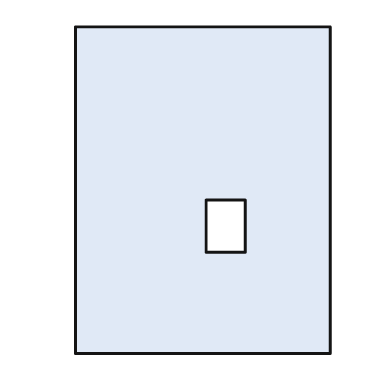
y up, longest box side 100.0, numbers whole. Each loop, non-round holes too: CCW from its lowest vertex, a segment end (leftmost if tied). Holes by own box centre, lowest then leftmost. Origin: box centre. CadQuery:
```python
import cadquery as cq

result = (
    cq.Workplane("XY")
    .moveTo(-39.0, -50.0)
    .lineTo(39.0, -50.0)
    .lineTo(39.0, 50.0)
    .lineTo(-39.0, 50.0)
    .close()
    .moveTo(1.0, -19.0)
    .lineTo(13.0, -19.0)
    .lineTo(13.0, -3.0)
    .lineTo(1.0, -3.0)
    .close()
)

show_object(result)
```